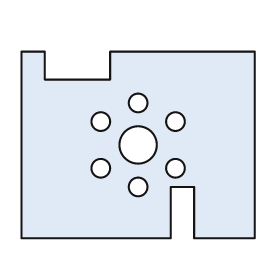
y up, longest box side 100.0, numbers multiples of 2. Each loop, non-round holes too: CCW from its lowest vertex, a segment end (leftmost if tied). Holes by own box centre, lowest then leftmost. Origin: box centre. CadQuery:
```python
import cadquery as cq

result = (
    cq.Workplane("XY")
    .moveTo(-50.0, -40.0)
    .lineTo(14.0, -40.0)
    .lineTo(14.0, -18.0)
    .lineTo(24.0, -18.0)
    .lineTo(24.0, -40.0)
    .lineTo(50.0, -40.0)
    .lineTo(50.0, 40.0)
    .lineTo(-12.0, 40.0)
    .lineTo(-12.0, 28.0)
    .lineTo(-40.0, 28.0)
    .lineTo(-40.0, 40.0)
    .lineTo(-50.0, 40.0)
    .close()
    .moveTo(0.0, -18.0)
    .circle(4.0)
    .moveTo(-16.0, -10.0)
    .circle(4.0)
    .moveTo(16.0, -10.0)
    .circle(4.0)
    .moveTo(0.0, 0.0)
    .circle(8.0)
    .moveTo(-16.0, 10.0)
    .circle(4.0)
    .moveTo(16.0, 10.0)
    .circle(4.0)
    .moveTo(0.0, 18.0)
    .circle(4.0)
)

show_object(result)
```